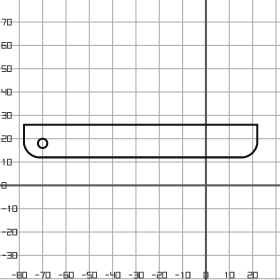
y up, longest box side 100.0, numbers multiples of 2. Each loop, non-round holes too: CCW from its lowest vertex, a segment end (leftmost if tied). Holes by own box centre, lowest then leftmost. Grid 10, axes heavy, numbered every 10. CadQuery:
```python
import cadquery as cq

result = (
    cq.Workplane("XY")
    .moveTo(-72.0, 12.0)
    .lineTo(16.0, 12.0)
    .threePointArc((20.0, 14.0), (22.0, 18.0))
    .lineTo(22.0, 26.0)
    .lineTo(-78.0, 26.0)
    .lineTo(-78.0, 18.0)
    .threePointArc((-76.0, 14.0), (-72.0, 12.0))
    .close()
    .moveTo(-70.0, 18.0)
    .circle(2.0)
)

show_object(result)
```